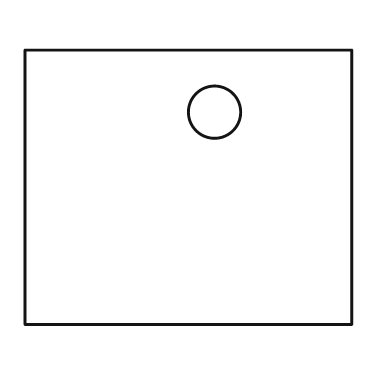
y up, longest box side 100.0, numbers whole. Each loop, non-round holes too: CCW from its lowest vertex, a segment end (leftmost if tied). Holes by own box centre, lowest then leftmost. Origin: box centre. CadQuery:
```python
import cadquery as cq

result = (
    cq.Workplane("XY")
    .moveTo(-50.0, -42.0)
    .lineTo(50.0, -42.0)
    .lineTo(50.0, 42.0)
    .lineTo(-50.0, 42.0)
    .close()
    .moveTo(8.0, 23.0)
    .circle(8.0)
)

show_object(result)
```